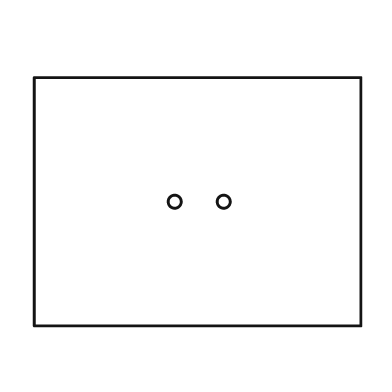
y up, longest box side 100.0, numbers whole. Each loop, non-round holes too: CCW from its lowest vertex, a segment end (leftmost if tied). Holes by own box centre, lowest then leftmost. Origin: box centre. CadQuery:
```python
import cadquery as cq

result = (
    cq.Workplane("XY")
    .moveTo(-50.0, -38.0)
    .lineTo(50.0, -38.0)
    .lineTo(50.0, 38.0)
    .lineTo(-50.0, 38.0)
    .close()
    .moveTo(-7.0, 0.0)
    .circle(2.0)
    .moveTo(8.0, 0.0)
    .circle(2.0)
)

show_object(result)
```